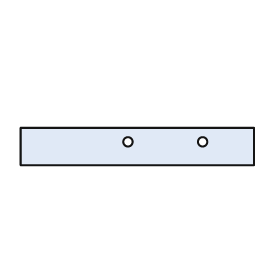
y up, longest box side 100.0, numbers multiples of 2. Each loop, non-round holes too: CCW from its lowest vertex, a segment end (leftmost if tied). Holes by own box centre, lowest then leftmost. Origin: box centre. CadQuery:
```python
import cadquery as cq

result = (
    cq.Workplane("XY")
    .moveTo(-50.0, -8.0)
    .lineTo(50.0, -8.0)
    .lineTo(50.0, 8.0)
    .lineTo(-50.0, 8.0)
    .close()
    .moveTo(-4.0, 2.0)
    .circle(2.0)
    .moveTo(28.0, 2.0)
    .circle(2.0)
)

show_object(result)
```